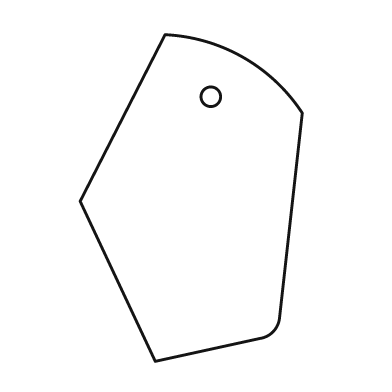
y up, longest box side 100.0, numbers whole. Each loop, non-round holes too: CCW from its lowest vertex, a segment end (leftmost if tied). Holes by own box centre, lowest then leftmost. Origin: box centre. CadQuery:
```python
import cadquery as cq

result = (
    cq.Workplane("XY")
    .moveTo(-11.0, -50.0)
    .lineTo(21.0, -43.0)
    .threePointArc((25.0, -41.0), (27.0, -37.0))
    .lineTo(34.0, 26.0)
    .threePointArc((16.0, 43.0), (-8.0, 50.0))
    .lineTo(-34.0, -1.0)
    .close()
    .moveTo(6.0, 31.0)
    .circle(3.0)
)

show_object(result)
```